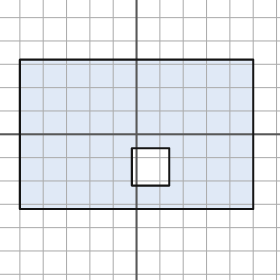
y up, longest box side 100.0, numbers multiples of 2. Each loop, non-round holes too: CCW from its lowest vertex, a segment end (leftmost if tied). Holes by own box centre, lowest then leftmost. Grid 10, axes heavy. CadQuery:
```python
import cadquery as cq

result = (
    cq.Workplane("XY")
    .moveTo(-50.0, -32.0)
    .lineTo(50.0, -32.0)
    .lineTo(50.0, 32.0)
    .lineTo(-50.0, 32.0)
    .close()
    .moveTo(-2.0, -22.0)
    .lineTo(14.0, -22.0)
    .lineTo(14.0, -6.0)
    .lineTo(-2.0, -6.0)
    .close()
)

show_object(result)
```